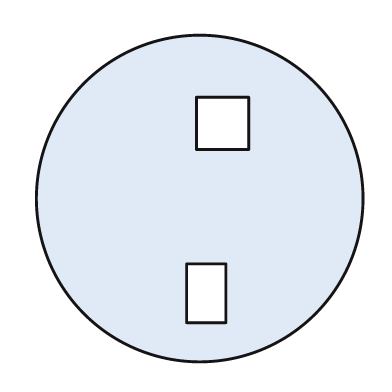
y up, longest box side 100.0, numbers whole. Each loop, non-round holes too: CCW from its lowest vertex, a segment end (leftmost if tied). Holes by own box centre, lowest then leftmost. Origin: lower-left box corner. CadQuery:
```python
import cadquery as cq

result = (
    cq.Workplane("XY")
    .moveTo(50.0, 50.0)
    .circle(50.0)
    .moveTo(46.0, 12.0)
    .lineTo(58.0, 12.0)
    .lineTo(58.0, 30.0)
    .lineTo(46.0, 30.0)
    .close()
    .moveTo(49.0, 65.0)
    .lineTo(65.0, 65.0)
    .lineTo(65.0, 81.0)
    .lineTo(49.0, 81.0)
    .close()
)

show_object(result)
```